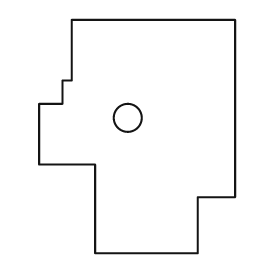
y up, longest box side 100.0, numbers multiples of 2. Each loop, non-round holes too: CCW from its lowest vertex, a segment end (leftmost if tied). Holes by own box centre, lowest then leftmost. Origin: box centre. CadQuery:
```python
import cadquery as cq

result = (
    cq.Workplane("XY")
    .moveTo(-18.0, -50.0)
    .lineTo(26.0, -50.0)
    .lineTo(26.0, -26.0)
    .lineTo(42.0, -26.0)
    .lineTo(42.0, 50.0)
    .lineTo(-28.0, 50.0)
    .lineTo(-28.0, 24.0)
    .lineTo(-32.0, 24.0)
    .lineTo(-32.0, 14.0)
    .lineTo(-42.0, 14.0)
    .lineTo(-42.0, -12.0)
    .lineTo(-18.0, -12.0)
    .close()
    .moveTo(-4.0, 8.0)
    .circle(6.0)
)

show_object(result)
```